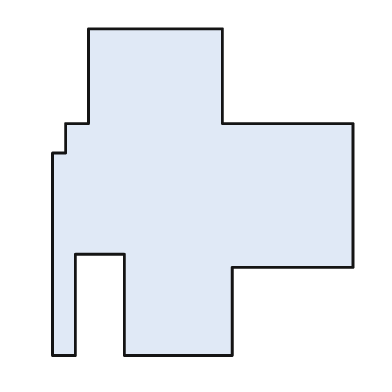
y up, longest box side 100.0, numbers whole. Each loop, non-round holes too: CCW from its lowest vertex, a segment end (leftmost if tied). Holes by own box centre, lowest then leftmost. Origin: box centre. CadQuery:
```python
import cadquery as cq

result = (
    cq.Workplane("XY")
    .moveTo(-46.0, -50.0)
    .lineTo(-39.0, -50.0)
    .lineTo(-39.0, -19.0)
    .lineTo(-24.0, -19.0)
    .lineTo(-24.0, -50.0)
    .lineTo(9.0, -50.0)
    .lineTo(9.0, -23.0)
    .lineTo(46.0, -23.0)
    .lineTo(46.0, 21.0)
    .lineTo(6.0, 21.0)
    .lineTo(6.0, 50.0)
    .lineTo(-35.0, 50.0)
    .lineTo(-35.0, 21.0)
    .lineTo(-42.0, 21.0)
    .lineTo(-42.0, 12.0)
    .lineTo(-46.0, 12.0)
    .close()
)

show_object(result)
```